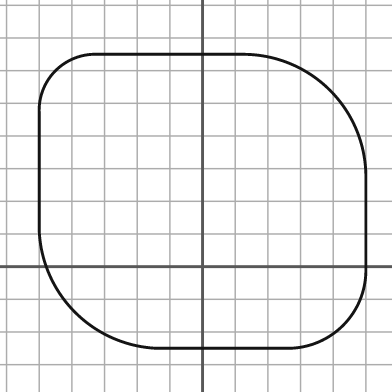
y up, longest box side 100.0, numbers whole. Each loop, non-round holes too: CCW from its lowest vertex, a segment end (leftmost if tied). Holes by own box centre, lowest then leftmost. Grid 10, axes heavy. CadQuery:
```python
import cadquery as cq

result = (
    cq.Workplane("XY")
    .moveTo(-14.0, -25.0)
    .lineTo(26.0, -25.0)
    .threePointArc((43.0, -18.0), (50.0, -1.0))
    .lineTo(50.0, 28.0)
    .threePointArc((39.0, 54.0), (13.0, 65.0))
    .lineTo(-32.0, 65.0)
    .threePointArc((-45.0, 60.0), (-50.0, 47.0))
    .lineTo(-50.0, 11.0)
    .threePointArc((-39.0, -14.0), (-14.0, -25.0))
    .close()
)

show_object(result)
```